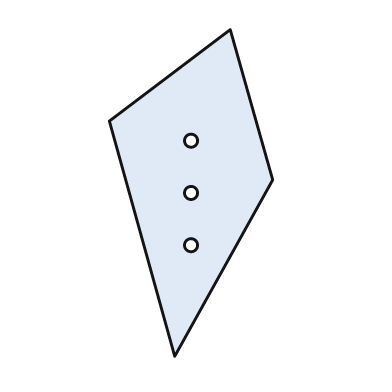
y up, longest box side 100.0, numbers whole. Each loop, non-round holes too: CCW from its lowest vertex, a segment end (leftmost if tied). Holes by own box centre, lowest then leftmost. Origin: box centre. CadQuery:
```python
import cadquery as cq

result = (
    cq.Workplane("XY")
    .moveTo(-5.0, -50.0)
    .lineTo(25.0, 4.0)
    .lineTo(12.0, 50.0)
    .lineTo(-25.0, 22.0)
    .close()
    .moveTo(0.0, -16.0)
    .circle(2.0)
    .moveTo(0.0, 0.0)
    .circle(2.0)
    .moveTo(0.0, 16.0)
    .circle(2.0)
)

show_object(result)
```